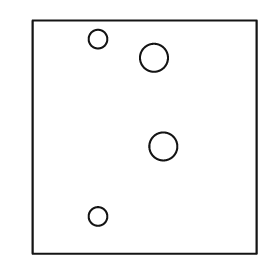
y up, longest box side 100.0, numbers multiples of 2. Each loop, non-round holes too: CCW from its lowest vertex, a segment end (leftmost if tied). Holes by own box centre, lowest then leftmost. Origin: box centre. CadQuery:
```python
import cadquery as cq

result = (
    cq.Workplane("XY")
    .moveTo(-48.0, -50.0)
    .lineTo(48.0, -50.0)
    .lineTo(48.0, 50.0)
    .lineTo(-48.0, 50.0)
    .close()
    .moveTo(-20.0, -34.0)
    .circle(4.0)
    .moveTo(8.0, -4.0)
    .circle(6.0)
    .moveTo(4.0, 34.0)
    .circle(6.0)
    .moveTo(-20.0, 42.0)
    .circle(4.0)
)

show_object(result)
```